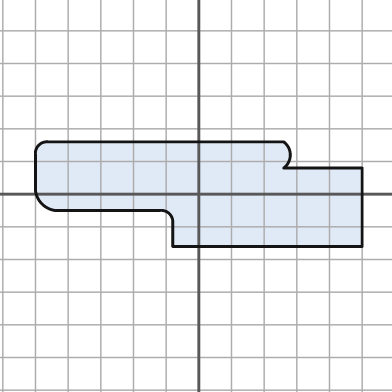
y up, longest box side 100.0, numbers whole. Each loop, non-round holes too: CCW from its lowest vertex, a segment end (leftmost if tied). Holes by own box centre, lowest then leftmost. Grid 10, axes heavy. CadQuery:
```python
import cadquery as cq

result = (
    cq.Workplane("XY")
    .moveTo(-8.0, -16.0)
    .lineTo(50.0, -16.0)
    .lineTo(50.0, 8.0)
    .lineTo(26.0, 8.0)
    .threePointArc((28.0, 12.0), (26.0, 16.0))
    .lineTo(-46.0, 16.0)
    .threePointArc((-49.0, 15.0), (-50.0, 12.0))
    .lineTo(-50.0, 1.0)
    .threePointArc((-48.0, -3.0), (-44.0, -5.0))
    .lineTo(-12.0, -5.0)
    .threePointArc((-9.0, -6.0), (-8.0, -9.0))
    .close()
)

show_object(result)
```